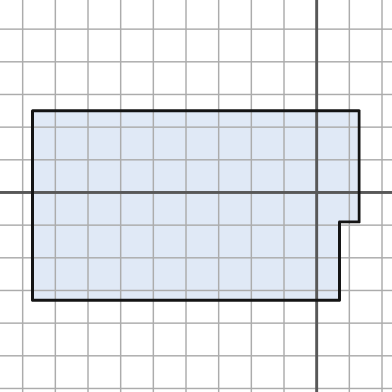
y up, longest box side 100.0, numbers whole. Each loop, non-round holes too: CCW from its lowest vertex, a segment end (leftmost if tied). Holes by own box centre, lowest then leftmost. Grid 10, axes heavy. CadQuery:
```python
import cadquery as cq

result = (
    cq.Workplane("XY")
    .moveTo(-87.0, -33.0)
    .lineTo(7.0, -33.0)
    .lineTo(7.0, -9.0)
    .lineTo(13.0, -9.0)
    .lineTo(13.0, 25.0)
    .lineTo(-87.0, 25.0)
    .close()
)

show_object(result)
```